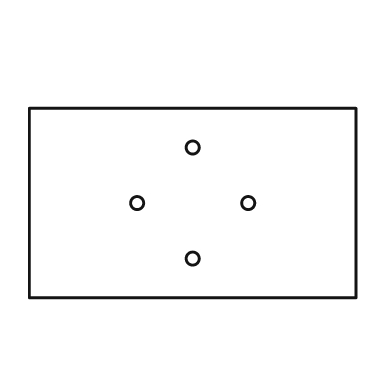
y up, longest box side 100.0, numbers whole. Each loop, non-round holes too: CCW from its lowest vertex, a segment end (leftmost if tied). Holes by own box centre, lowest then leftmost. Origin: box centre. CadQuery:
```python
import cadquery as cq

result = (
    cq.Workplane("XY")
    .moveTo(-50.0, -29.0)
    .lineTo(50.0, -29.0)
    .lineTo(50.0, 29.0)
    .lineTo(-50.0, 29.0)
    .close()
    .moveTo(0.0, -17.0)
    .circle(2.0)
    .moveTo(-17.0, 0.0)
    .circle(2.0)
    .moveTo(17.0, 0.0)
    .circle(2.0)
    .moveTo(0.0, 17.0)
    .circle(2.0)
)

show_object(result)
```